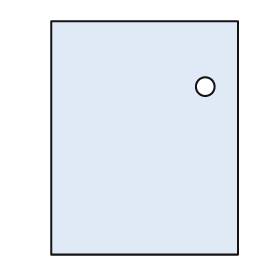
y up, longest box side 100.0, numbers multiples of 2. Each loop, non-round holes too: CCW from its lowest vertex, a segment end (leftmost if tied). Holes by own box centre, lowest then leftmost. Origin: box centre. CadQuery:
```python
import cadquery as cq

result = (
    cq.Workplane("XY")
    .moveTo(-40.0, -50.0)
    .lineTo(40.0, -50.0)
    .lineTo(40.0, 50.0)
    .lineTo(-40.0, 50.0)
    .close()
    .moveTo(26.0, 22.0)
    .circle(4.0)
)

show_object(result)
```